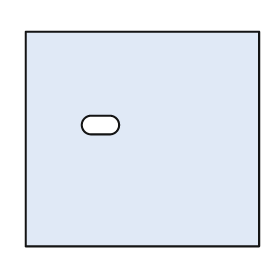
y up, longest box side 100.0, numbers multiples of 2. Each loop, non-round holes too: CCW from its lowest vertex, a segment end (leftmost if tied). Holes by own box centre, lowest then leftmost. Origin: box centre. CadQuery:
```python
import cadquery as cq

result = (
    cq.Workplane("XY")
    .moveTo(-50.0, -46.0)
    .lineTo(50.0, -46.0)
    .lineTo(50.0, 46.0)
    .lineTo(-50.0, 46.0)
    .close()
    .moveTo(-22.0, 2.0)
    .lineTo(-14.0, 2.0)
    .threePointArc((-10.0, 6.0), (-14.0, 10.0))
    .lineTo(-22.0, 10.0)
    .threePointArc((-26.0, 6.0), (-22.0, 2.0))
    .close()
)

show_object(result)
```